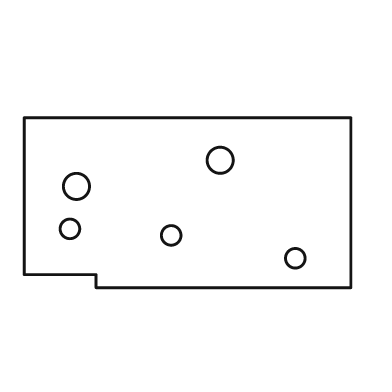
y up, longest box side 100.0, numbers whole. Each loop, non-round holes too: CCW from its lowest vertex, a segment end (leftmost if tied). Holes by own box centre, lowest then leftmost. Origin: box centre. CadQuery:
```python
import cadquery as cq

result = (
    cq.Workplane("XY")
    .moveTo(-28.0, -26.0)
    .lineTo(50.0, -26.0)
    .lineTo(50.0, 26.0)
    .lineTo(-50.0, 26.0)
    .lineTo(-50.0, -22.0)
    .lineTo(-28.0, -22.0)
    .close()
    .moveTo(33.0, -17.0)
    .circle(3.0)
    .moveTo(-5.0, -10.0)
    .circle(3.0)
    .moveTo(-36.0, -8.0)
    .circle(3.0)
    .moveTo(-34.0, 5.0)
    .circle(4.0)
    .moveTo(10.0, 13.0)
    .circle(4.0)
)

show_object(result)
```